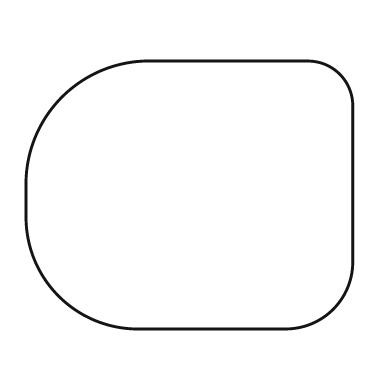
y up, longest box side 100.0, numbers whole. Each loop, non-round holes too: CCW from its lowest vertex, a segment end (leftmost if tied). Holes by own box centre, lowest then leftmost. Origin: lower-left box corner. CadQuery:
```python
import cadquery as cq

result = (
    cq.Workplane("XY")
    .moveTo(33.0, 0.0)
    .lineTo(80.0, 0.0)
    .threePointArc((94.0, 6.0), (100.0, 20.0))
    .lineTo(100.0, 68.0)
    .threePointArc((96.0, 78.0), (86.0, 82.0))
    .lineTo(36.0, 82.0)
    .threePointArc((11.0, 71.0), (0.0, 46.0))
    .lineTo(0.0, 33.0)
    .threePointArc((10.0, 10.0), (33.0, 0.0))
    .close()
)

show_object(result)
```